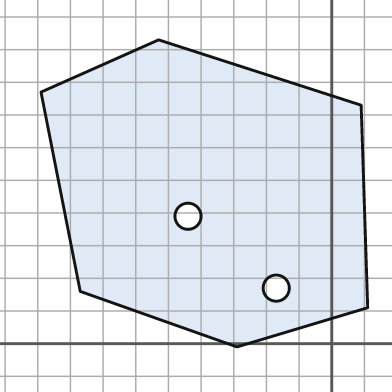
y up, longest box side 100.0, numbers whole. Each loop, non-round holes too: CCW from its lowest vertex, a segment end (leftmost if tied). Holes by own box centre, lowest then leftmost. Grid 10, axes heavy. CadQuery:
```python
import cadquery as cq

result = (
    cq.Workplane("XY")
    .moveTo(-29.0, -1.0)
    .lineTo(11.0, 11.0)
    .lineTo(9.0, 73.0)
    .lineTo(-53.0, 93.0)
    .lineTo(-89.0, 77.0)
    .lineTo(-77.0, 16.0)
    .close()
    .moveTo(-17.0, 17.0)
    .circle(4.0)
    .moveTo(-44.0, 39.0)
    .circle(4.0)
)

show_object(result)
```